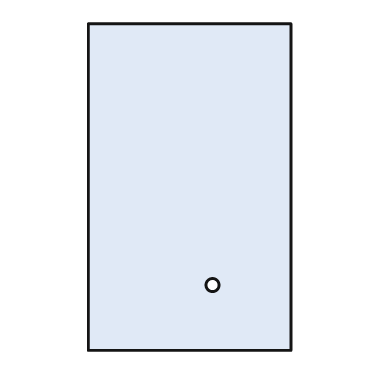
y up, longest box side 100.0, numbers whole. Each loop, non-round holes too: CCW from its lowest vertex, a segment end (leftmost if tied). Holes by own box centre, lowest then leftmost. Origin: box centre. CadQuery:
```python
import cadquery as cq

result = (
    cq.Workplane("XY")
    .moveTo(-31.0, -50.0)
    .lineTo(31.0, -50.0)
    .lineTo(31.0, 50.0)
    .lineTo(-31.0, 50.0)
    .close()
    .moveTo(7.0, -30.0)
    .circle(2.0)
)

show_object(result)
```